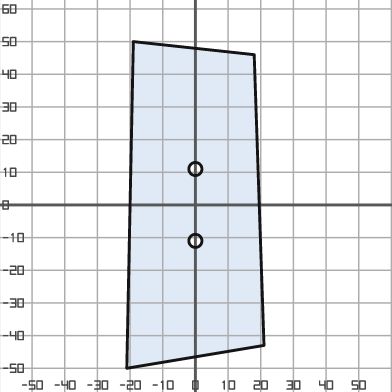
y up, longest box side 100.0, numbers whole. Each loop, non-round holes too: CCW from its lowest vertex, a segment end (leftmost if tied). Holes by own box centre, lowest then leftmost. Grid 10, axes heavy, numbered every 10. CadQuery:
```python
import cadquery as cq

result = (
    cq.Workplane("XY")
    .moveTo(-21.0, -50.0)
    .lineTo(21.0, -43.0)
    .lineTo(18.0, 46.0)
    .lineTo(-19.0, 50.0)
    .close()
    .moveTo(0.0, -11.0)
    .circle(2.0)
    .moveTo(0.0, 11.0)
    .circle(2.0)
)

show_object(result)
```